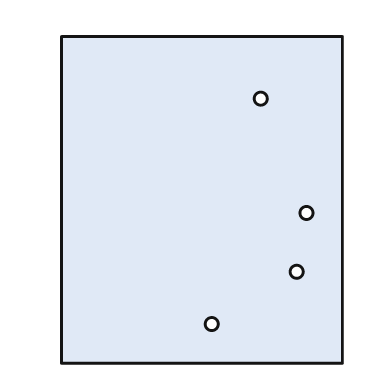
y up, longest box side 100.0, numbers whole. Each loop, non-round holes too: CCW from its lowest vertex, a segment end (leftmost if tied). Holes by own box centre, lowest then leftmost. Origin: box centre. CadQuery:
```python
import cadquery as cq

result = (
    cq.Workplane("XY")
    .moveTo(-43.0, -50.0)
    .lineTo(43.0, -50.0)
    .lineTo(43.0, 50.0)
    .lineTo(-43.0, 50.0)
    .close()
    .moveTo(3.0, -38.0)
    .circle(2.0)
    .moveTo(29.0, -22.0)
    .circle(2.0)
    .moveTo(32.0, -4.0)
    .circle(2.0)
    .moveTo(18.0, 31.0)
    .circle(2.0)
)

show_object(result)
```